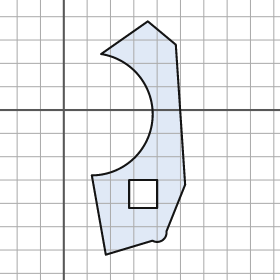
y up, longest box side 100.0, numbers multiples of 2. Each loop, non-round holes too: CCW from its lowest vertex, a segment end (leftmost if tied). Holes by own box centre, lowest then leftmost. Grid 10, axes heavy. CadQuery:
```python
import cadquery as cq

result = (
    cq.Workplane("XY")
    .moveTo(18.0, -62.0)
    .lineTo(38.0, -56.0)
    .threePointArc((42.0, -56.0), (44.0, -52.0))
    .lineTo(52.0, -32.0)
    .lineTo(48.0, 28.0)
    .lineTo(36.0, 38.0)
    .lineTo(16.0, 24.0)
    .threePointArc((38.0, -4.0), (12.0, -28.0))
    .close()
    .moveTo(28.0, -42.0)
    .lineTo(40.0, -42.0)
    .lineTo(40.0, -30.0)
    .lineTo(28.0, -30.0)
    .close()
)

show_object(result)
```